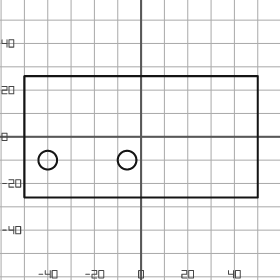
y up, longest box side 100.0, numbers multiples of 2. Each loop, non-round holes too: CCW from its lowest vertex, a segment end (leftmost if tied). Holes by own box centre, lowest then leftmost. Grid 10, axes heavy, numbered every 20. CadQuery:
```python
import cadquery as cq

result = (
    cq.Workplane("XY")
    .moveTo(-50.0, -26.0)
    .lineTo(50.0, -26.0)
    .lineTo(50.0, 26.0)
    .lineTo(-50.0, 26.0)
    .close()
    .moveTo(-40.0, -10.0)
    .circle(4.0)
    .moveTo(-6.0, -10.0)
    .circle(4.0)
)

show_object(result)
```